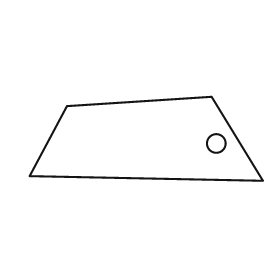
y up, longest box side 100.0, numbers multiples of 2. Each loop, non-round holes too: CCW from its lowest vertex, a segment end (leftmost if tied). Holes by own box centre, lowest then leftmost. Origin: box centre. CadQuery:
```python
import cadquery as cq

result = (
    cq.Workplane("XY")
    .moveTo(50.0, -18.0)
    .lineTo(28.0, 18.0)
    .lineTo(-34.0, 14.0)
    .lineTo(-50.0, -16.0)
    .close()
    .moveTo(30.0, -2.0)
    .circle(4.0)
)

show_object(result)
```